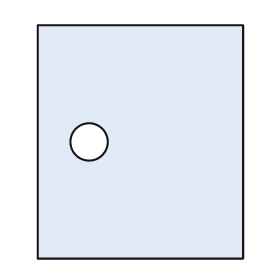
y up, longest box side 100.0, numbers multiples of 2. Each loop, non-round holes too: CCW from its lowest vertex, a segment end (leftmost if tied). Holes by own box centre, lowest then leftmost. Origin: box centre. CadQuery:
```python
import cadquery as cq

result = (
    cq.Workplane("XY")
    .moveTo(-44.0, -50.0)
    .lineTo(44.0, -50.0)
    .lineTo(44.0, 50.0)
    .lineTo(-44.0, 50.0)
    .close()
    .moveTo(-22.0, 0.0)
    .circle(8.0)
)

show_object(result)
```